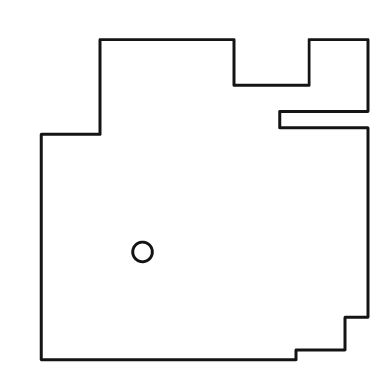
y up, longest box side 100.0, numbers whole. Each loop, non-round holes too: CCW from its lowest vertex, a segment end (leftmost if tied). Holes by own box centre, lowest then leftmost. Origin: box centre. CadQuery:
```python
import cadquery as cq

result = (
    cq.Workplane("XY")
    .moveTo(-50.0, -49.0)
    .lineTo(28.0, -49.0)
    .lineTo(28.0, -46.0)
    .lineTo(43.0, -46.0)
    .lineTo(43.0, -36.0)
    .lineTo(50.0, -36.0)
    .lineTo(50.0, 22.0)
    .lineTo(23.0, 22.0)
    .lineTo(23.0, 27.0)
    .lineTo(50.0, 27.0)
    .lineTo(50.0, 49.0)
    .lineTo(32.0, 49.0)
    .lineTo(32.0, 35.0)
    .lineTo(9.0, 35.0)
    .lineTo(9.0, 49.0)
    .lineTo(-32.0, 49.0)
    .lineTo(-32.0, 20.0)
    .lineTo(-50.0, 20.0)
    .close()
    .moveTo(-19.0, -16.0)
    .circle(3.0)
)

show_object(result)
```